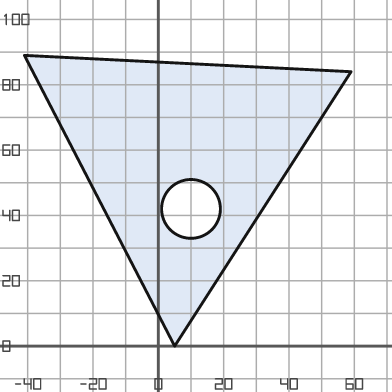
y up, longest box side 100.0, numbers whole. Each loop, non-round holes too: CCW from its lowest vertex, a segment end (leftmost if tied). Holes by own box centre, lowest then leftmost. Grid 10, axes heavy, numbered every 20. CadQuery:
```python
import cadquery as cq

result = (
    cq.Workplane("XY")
    .moveTo(5.0, 0.0)
    .lineTo(59.0, 84.0)
    .lineTo(-41.0, 89.0)
    .close()
    .moveTo(10.0, 42.0)
    .circle(9.0)
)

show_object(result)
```